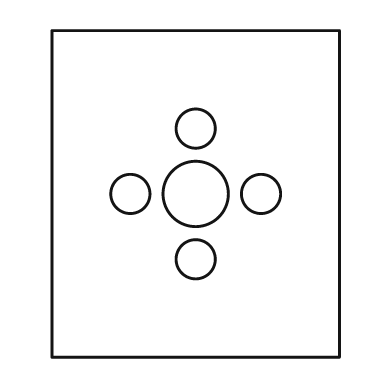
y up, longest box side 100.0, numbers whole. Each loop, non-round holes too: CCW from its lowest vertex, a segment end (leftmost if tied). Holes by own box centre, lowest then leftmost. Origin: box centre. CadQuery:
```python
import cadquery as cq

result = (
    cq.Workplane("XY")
    .moveTo(-44.0, -50.0)
    .lineTo(44.0, -50.0)
    .lineTo(44.0, 50.0)
    .lineTo(-44.0, 50.0)
    .close()
    .moveTo(0.0, -20.0)
    .circle(6.0)
    .moveTo(-20.0, 0.0)
    .circle(6.0)
    .moveTo(0.0, 0.0)
    .circle(10.0)
    .moveTo(20.0, 0.0)
    .circle(6.0)
    .moveTo(0.0, 20.0)
    .circle(6.0)
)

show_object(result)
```